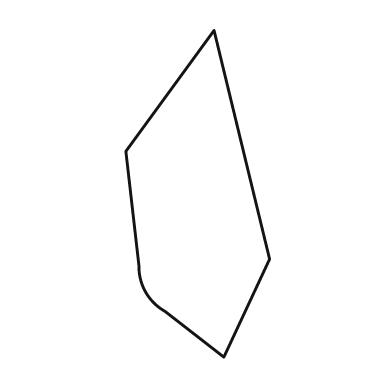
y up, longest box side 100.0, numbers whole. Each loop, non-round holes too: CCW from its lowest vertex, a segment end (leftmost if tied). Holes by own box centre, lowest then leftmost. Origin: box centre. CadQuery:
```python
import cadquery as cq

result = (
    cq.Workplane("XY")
    .moveTo(8.0, -50.0)
    .lineTo(22.0, -20.0)
    .lineTo(5.0, 50.0)
    .lineTo(-22.0, 13.0)
    .lineTo(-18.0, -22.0)
    .threePointArc((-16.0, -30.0), (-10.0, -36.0))
    .close()
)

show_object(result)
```